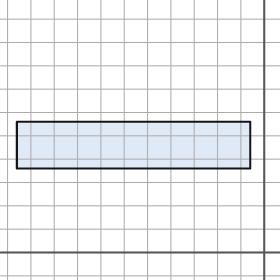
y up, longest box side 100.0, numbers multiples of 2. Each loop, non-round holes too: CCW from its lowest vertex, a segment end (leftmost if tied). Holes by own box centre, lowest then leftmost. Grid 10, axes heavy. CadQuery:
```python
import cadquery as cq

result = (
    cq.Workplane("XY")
    .moveTo(-106.0, 36.0)
    .lineTo(-6.0, 36.0)
    .lineTo(-6.0, 56.0)
    .lineTo(-106.0, 56.0)
    .close()
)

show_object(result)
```